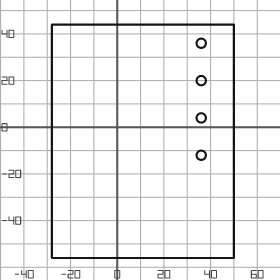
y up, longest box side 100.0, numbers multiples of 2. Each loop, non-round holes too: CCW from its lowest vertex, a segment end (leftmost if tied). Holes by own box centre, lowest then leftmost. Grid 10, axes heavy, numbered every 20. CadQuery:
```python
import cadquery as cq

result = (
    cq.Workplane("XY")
    .moveTo(-28.0, -56.0)
    .lineTo(50.0, -56.0)
    .lineTo(50.0, 44.0)
    .lineTo(-28.0, 44.0)
    .close()
    .moveTo(36.0, -12.0)
    .circle(2.0)
    .moveTo(36.0, 4.0)
    .circle(2.0)
    .moveTo(36.0, 20.0)
    .circle(2.0)
    .moveTo(36.0, 36.0)
    .circle(2.0)
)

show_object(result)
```